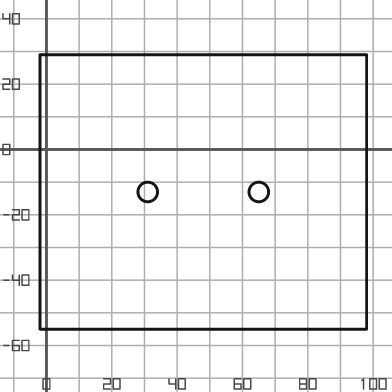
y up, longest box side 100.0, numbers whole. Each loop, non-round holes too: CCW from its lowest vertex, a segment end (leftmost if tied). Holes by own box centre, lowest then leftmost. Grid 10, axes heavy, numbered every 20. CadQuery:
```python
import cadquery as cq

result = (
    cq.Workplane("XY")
    .moveTo(-2.0, -55.0)
    .lineTo(98.0, -55.0)
    .lineTo(98.0, 29.0)
    .lineTo(-2.0, 29.0)
    .close()
    .moveTo(31.0, -13.0)
    .circle(3.0)
    .moveTo(65.0, -13.0)
    .circle(3.0)
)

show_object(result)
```